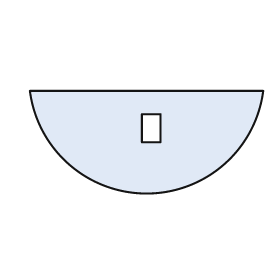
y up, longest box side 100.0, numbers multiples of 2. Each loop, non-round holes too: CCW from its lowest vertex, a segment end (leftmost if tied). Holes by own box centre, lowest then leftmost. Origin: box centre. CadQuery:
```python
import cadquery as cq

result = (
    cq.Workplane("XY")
    .moveTo(-50.0, 22.0)
    .threePointArc((0.0, -22.0), (50.0, 22.0))
    .close()
    .moveTo(-2.0, 0.0)
    .lineTo(6.0, 0.0)
    .lineTo(6.0, 12.0)
    .lineTo(-2.0, 12.0)
    .close()
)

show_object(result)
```